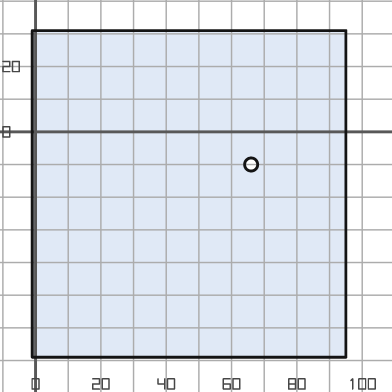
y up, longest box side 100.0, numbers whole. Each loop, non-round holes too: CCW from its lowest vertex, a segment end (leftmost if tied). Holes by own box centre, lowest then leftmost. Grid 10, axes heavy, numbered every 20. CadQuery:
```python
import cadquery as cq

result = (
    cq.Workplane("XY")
    .moveTo(-1.0, -69.0)
    .lineTo(95.0, -69.0)
    .lineTo(95.0, 31.0)
    .lineTo(-1.0, 31.0)
    .close()
    .moveTo(66.0, -10.0)
    .circle(2.0)
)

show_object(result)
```